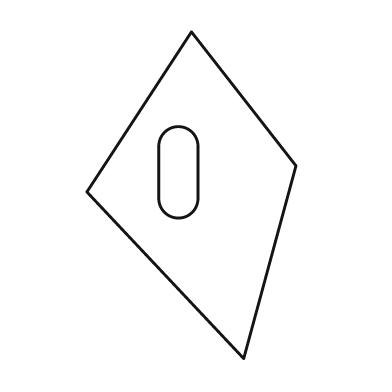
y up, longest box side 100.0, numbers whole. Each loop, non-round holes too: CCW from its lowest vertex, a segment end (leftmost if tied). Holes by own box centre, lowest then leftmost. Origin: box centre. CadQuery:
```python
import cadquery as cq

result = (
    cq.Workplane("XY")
    .moveTo(16.0, -50.0)
    .lineTo(32.0, 9.0)
    .lineTo(0.0, 50.0)
    .lineTo(-32.0, 1.0)
    .close()
    .moveTo(-10.0, -1.0)
    .threePointArc((-4.0, -7.0), (2.0, -1.0))
    .lineTo(2.0, 15.0)
    .threePointArc((-4.0, 21.0), (-10.0, 15.0))
    .close()
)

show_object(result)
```